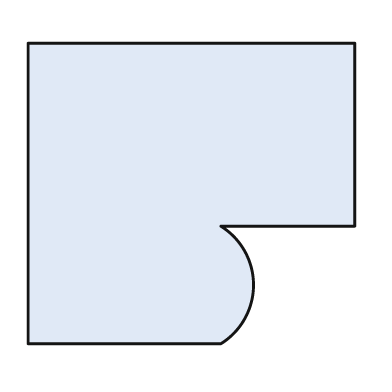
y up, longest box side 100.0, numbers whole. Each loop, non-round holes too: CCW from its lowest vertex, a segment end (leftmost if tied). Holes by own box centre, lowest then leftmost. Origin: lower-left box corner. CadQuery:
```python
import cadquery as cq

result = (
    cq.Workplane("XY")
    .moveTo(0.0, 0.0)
    .lineTo(59.0, 0.0)
    .threePointArc((69.0, 18.0), (59.0, 36.0))
    .lineTo(100.0, 36.0)
    .lineTo(100.0, 92.0)
    .lineTo(0.0, 92.0)
    .close()
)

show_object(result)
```